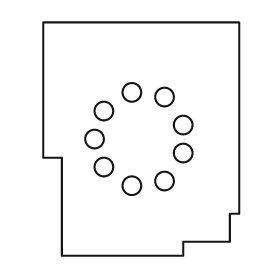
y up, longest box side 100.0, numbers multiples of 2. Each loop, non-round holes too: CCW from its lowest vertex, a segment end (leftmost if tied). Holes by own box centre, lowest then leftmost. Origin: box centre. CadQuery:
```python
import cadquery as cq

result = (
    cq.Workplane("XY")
    .moveTo(-34.0, -50.0)
    .lineTo(18.0, -50.0)
    .lineTo(18.0, -44.0)
    .lineTo(38.0, -44.0)
    .lineTo(38.0, -32.0)
    .lineTo(42.0, -32.0)
    .lineTo(42.0, 50.0)
    .lineTo(-42.0, 50.0)
    .lineTo(-42.0, -8.0)
    .lineTo(-34.0, -8.0)
    .close()
    .moveTo(-4.0, -20.0)
    .circle(4.0)
    .moveTo(10.0, -18.0)
    .circle(4.0)
    .moveTo(-16.0, -12.0)
    .circle(4.0)
    .moveTo(18.0, -6.0)
    .circle(4.0)
    .moveTo(-20.0, 0.0)
    .circle(4.0)
    .moveTo(18.0, 6.0)
    .circle(4.0)
    .moveTo(-16.0, 12.0)
    .circle(4.0)
    .moveTo(10.0, 18.0)
    .circle(4.0)
    .moveTo(-4.0, 20.0)
    .circle(4.0)
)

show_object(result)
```